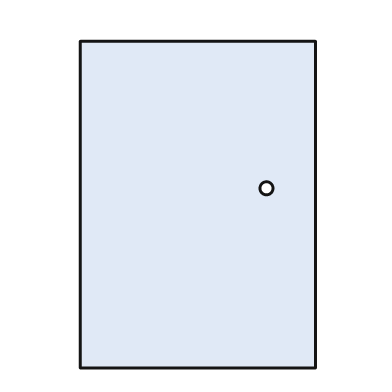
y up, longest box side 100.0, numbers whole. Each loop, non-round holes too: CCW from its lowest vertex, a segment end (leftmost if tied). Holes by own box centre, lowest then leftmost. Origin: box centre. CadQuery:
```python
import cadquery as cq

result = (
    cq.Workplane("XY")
    .moveTo(-36.0, -50.0)
    .lineTo(36.0, -50.0)
    .lineTo(36.0, 50.0)
    .lineTo(-36.0, 50.0)
    .close()
    .moveTo(21.0, 5.0)
    .circle(2.0)
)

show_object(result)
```